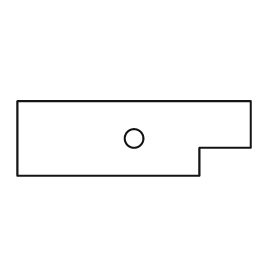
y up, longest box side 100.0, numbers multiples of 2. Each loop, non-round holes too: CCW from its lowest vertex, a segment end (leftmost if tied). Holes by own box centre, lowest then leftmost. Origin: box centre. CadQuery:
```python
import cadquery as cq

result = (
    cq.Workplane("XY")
    .moveTo(-50.0, -16.0)
    .lineTo(28.0, -16.0)
    .lineTo(28.0, -4.0)
    .lineTo(50.0, -4.0)
    .lineTo(50.0, 16.0)
    .lineTo(-50.0, 16.0)
    .close()
    .moveTo(0.0, 0.0)
    .circle(4.0)
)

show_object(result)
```